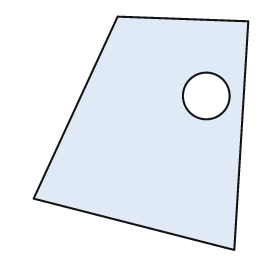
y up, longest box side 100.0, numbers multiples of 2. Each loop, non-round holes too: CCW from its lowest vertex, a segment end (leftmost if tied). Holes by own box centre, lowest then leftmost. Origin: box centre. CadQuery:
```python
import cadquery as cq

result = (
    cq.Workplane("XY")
    .moveTo(40.0, -50.0)
    .lineTo(46.0, 48.0)
    .lineTo(-10.0, 50.0)
    .lineTo(-46.0, -28.0)
    .close()
    .moveTo(28.0, 16.0)
    .circle(10.0)
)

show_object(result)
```